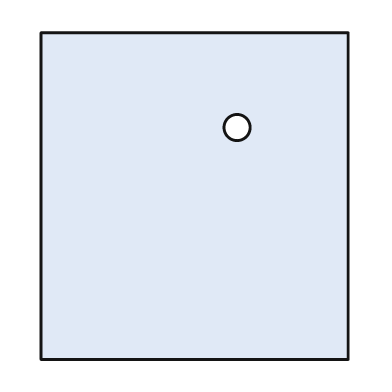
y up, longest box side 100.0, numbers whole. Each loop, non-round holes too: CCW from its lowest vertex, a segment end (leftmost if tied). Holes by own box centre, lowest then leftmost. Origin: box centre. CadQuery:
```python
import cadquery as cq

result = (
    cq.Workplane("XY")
    .moveTo(-47.0, -50.0)
    .lineTo(47.0, -50.0)
    .lineTo(47.0, 50.0)
    .lineTo(-47.0, 50.0)
    .close()
    .moveTo(13.0, 21.0)
    .circle(4.0)
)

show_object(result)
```